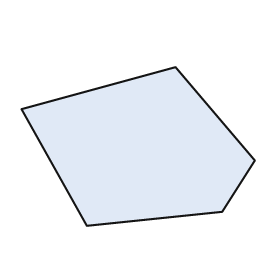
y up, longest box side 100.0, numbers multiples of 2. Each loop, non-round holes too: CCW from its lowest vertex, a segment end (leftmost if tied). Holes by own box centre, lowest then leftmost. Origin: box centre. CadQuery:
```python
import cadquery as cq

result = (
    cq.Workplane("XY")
    .moveTo(-22.0, -34.0)
    .lineTo(36.0, -28.0)
    .lineTo(50.0, -6.0)
    .lineTo(16.0, 34.0)
    .lineTo(-50.0, 16.0)
    .close()
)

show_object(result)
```